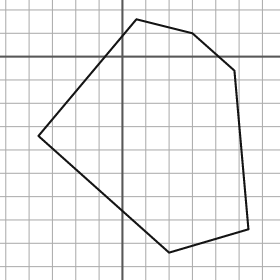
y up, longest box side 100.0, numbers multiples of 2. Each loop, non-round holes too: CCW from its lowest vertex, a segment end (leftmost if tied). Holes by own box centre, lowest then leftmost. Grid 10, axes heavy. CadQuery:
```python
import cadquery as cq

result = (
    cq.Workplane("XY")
    .moveTo(20.0, -84.0)
    .lineTo(54.0, -74.0)
    .lineTo(48.0, -6.0)
    .lineTo(30.0, 10.0)
    .lineTo(6.0, 16.0)
    .lineTo(-36.0, -34.0)
    .close()
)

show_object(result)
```